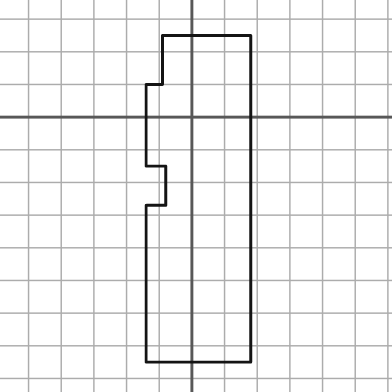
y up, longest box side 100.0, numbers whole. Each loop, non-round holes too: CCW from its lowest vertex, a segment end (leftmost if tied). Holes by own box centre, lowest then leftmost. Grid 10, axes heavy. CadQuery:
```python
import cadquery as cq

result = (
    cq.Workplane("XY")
    .moveTo(-14.0, -75.0)
    .lineTo(18.0, -75.0)
    .lineTo(18.0, 25.0)
    .lineTo(-9.0, 25.0)
    .lineTo(-9.0, 10.0)
    .lineTo(-14.0, 10.0)
    .lineTo(-14.0, -15.0)
    .lineTo(-8.0, -15.0)
    .lineTo(-8.0, -27.0)
    .lineTo(-14.0, -27.0)
    .close()
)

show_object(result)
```